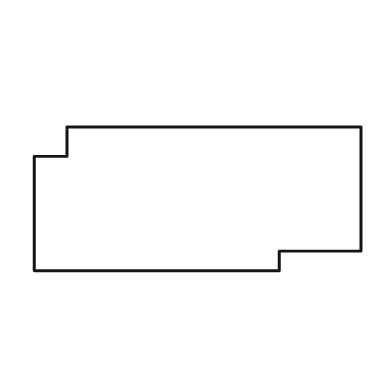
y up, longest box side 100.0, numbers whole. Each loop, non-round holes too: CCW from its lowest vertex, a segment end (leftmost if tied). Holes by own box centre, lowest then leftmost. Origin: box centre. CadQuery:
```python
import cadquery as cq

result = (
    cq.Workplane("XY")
    .moveTo(-50.0, -22.0)
    .lineTo(25.0, -22.0)
    .lineTo(25.0, -16.0)
    .lineTo(50.0, -16.0)
    .lineTo(50.0, 22.0)
    .lineTo(-40.0, 22.0)
    .lineTo(-40.0, 13.0)
    .lineTo(-50.0, 13.0)
    .close()
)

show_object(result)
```